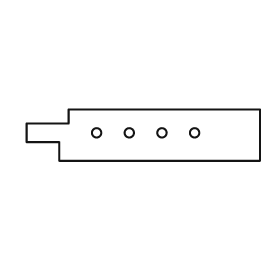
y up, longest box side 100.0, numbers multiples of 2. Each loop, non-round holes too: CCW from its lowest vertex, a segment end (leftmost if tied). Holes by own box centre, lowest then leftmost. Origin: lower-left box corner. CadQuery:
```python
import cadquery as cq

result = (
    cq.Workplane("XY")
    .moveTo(14.0, 0.0)
    .lineTo(100.0, 0.0)
    .lineTo(100.0, 22.0)
    .lineTo(18.0, 22.0)
    .lineTo(18.0, 16.0)
    .lineTo(0.0, 16.0)
    .lineTo(0.0, 8.0)
    .lineTo(14.0, 8.0)
    .close()
    .moveTo(30.0, 12.0)
    .circle(2.0)
    .moveTo(44.0, 12.0)
    .circle(2.0)
    .moveTo(58.0, 12.0)
    .circle(2.0)
    .moveTo(72.0, 12.0)
    .circle(2.0)
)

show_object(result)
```